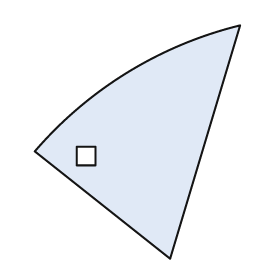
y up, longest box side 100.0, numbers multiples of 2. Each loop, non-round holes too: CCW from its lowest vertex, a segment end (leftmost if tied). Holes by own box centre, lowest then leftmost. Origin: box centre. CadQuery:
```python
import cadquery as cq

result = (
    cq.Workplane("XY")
    .moveTo(14.0, -50.0)
    .lineTo(44.0, 50.0)
    .threePointArc((-4.0, 30.0), (-44.0, -4.0))
    .close()
    .moveTo(-26.0, -10.0)
    .lineTo(-18.0, -10.0)
    .lineTo(-18.0, -2.0)
    .lineTo(-26.0, -2.0)
    .close()
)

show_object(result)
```